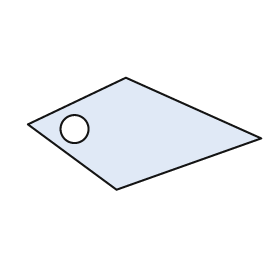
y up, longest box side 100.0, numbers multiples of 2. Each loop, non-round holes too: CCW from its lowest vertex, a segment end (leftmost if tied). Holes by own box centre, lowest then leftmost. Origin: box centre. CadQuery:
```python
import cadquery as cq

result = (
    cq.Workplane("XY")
    .moveTo(-12.0, -24.0)
    .lineTo(50.0, -2.0)
    .lineTo(-8.0, 24.0)
    .lineTo(-50.0, 4.0)
    .close()
    .moveTo(-30.0, 2.0)
    .circle(6.0)
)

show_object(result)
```